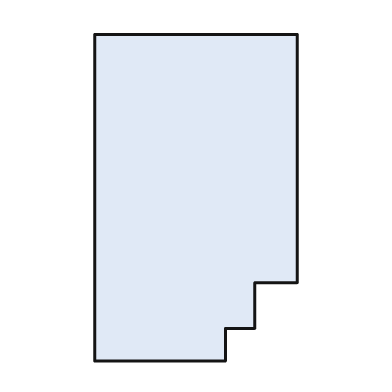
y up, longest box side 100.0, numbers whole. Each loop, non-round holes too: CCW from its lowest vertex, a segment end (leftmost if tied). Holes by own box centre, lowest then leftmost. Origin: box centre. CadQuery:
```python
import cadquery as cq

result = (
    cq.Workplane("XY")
    .moveTo(-31.0, -50.0)
    .lineTo(9.0, -50.0)
    .lineTo(9.0, -40.0)
    .lineTo(18.0, -40.0)
    .lineTo(18.0, -26.0)
    .lineTo(31.0, -26.0)
    .lineTo(31.0, 50.0)
    .lineTo(-31.0, 50.0)
    .close()
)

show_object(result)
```